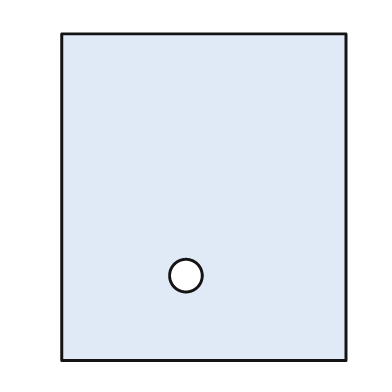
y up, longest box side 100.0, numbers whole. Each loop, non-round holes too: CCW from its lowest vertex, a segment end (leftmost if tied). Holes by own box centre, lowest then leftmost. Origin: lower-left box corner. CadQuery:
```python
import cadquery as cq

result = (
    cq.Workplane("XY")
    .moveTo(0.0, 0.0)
    .lineTo(87.0, 0.0)
    .lineTo(87.0, 100.0)
    .lineTo(0.0, 100.0)
    .close()
    .moveTo(38.0, 26.0)
    .circle(5.0)
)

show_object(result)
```